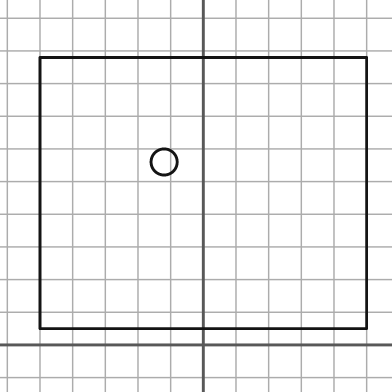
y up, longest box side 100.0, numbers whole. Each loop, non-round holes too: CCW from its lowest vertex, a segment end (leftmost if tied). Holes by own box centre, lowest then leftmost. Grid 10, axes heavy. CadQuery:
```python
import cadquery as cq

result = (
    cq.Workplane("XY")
    .moveTo(-50.0, 5.0)
    .lineTo(50.0, 5.0)
    .lineTo(50.0, 88.0)
    .lineTo(-50.0, 88.0)
    .close()
    .moveTo(-12.0, 56.0)
    .circle(4.0)
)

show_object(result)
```